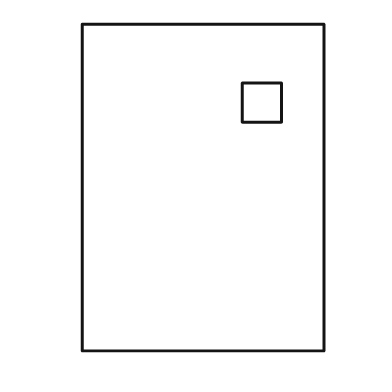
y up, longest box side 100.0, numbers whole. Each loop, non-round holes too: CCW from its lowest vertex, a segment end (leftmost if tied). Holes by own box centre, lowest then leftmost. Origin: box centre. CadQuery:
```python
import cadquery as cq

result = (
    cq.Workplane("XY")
    .moveTo(-37.0, -50.0)
    .lineTo(37.0, -50.0)
    .lineTo(37.0, 50.0)
    .lineTo(-37.0, 50.0)
    .close()
    .moveTo(12.0, 20.0)
    .lineTo(24.0, 20.0)
    .lineTo(24.0, 32.0)
    .lineTo(12.0, 32.0)
    .close()
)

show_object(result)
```